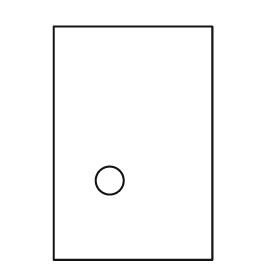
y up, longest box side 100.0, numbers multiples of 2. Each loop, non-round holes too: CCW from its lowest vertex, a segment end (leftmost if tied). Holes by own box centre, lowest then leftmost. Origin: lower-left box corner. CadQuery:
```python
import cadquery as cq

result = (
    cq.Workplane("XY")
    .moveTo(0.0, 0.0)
    .lineTo(68.0, 0.0)
    .lineTo(68.0, 100.0)
    .lineTo(0.0, 100.0)
    .close()
    .moveTo(24.0, 34.0)
    .circle(6.0)
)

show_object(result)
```